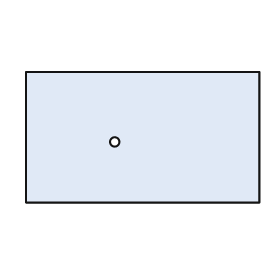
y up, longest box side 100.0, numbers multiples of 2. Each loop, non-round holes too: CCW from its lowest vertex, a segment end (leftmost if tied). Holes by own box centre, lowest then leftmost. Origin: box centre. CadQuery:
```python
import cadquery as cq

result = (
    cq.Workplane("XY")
    .moveTo(-50.0, -28.0)
    .lineTo(50.0, -28.0)
    .lineTo(50.0, 28.0)
    .lineTo(-50.0, 28.0)
    .close()
    .moveTo(-12.0, -2.0)
    .circle(2.0)
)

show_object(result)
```